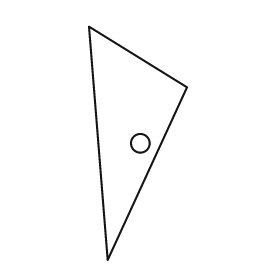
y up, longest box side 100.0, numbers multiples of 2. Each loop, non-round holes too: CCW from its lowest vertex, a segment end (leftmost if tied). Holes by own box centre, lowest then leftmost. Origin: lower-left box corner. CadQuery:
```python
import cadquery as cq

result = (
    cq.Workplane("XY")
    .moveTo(8.0, 0.0)
    .lineTo(42.0, 74.0)
    .lineTo(0.0, 100.0)
    .close()
    .moveTo(22.0, 50.0)
    .circle(4.0)
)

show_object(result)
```